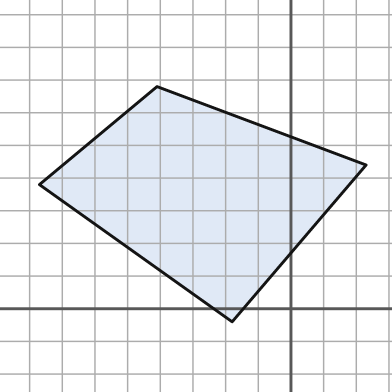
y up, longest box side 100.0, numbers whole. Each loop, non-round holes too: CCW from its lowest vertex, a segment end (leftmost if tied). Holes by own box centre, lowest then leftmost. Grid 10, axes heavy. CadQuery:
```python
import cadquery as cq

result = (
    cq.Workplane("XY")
    .moveTo(-18.0, -4.0)
    .lineTo(23.0, 44.0)
    .lineTo(-41.0, 68.0)
    .lineTo(-77.0, 38.0)
    .close()
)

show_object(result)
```